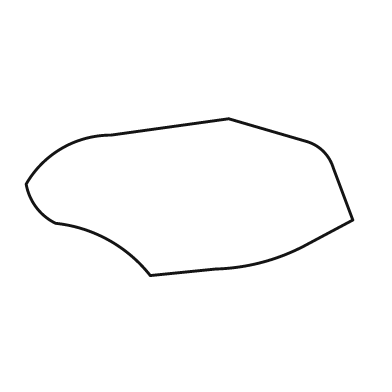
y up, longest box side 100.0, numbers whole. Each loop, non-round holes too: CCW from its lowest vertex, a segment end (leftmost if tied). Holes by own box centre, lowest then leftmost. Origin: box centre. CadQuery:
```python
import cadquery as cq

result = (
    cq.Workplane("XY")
    .moveTo(-12.0, -24.0)
    .lineTo(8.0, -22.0)
    .threePointArc((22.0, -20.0), (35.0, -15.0))
    .lineTo(50.0, -7.0)
    .lineTo(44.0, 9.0)
    .threePointArc((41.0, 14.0), (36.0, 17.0))
    .lineTo(12.0, 24.0)
    .lineTo(-24.0, 19.0)
    .threePointArc((-39.0, 15.0), (-50.0, 4.0))
    .threePointArc((-47.0, -3.0), (-41.0, -8.0))
    .threePointArc((-25.0, -13.0), (-12.0, -24.0))
    .close()
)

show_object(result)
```